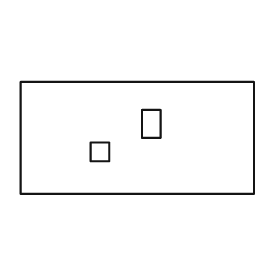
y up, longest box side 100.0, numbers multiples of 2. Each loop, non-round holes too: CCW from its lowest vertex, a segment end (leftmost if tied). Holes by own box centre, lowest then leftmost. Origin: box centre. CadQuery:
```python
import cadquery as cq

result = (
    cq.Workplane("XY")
    .moveTo(-50.0, -24.0)
    .lineTo(50.0, -24.0)
    .lineTo(50.0, 24.0)
    .lineTo(-50.0, 24.0)
    .close()
    .moveTo(-20.0, -10.0)
    .lineTo(-12.0, -10.0)
    .lineTo(-12.0, -2.0)
    .lineTo(-20.0, -2.0)
    .close()
    .moveTo(2.0, 0.0)
    .lineTo(10.0, 0.0)
    .lineTo(10.0, 12.0)
    .lineTo(2.0, 12.0)
    .close()
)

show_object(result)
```